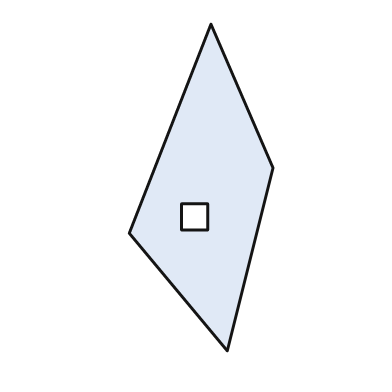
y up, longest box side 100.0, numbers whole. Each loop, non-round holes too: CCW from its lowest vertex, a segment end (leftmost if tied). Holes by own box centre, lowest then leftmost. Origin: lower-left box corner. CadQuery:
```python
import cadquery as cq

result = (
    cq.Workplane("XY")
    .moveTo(30.0, 0.0)
    .lineTo(44.0, 56.0)
    .lineTo(25.0, 100.0)
    .lineTo(0.0, 36.0)
    .close()
    .moveTo(16.0, 37.0)
    .lineTo(24.0, 37.0)
    .lineTo(24.0, 45.0)
    .lineTo(16.0, 45.0)
    .close()
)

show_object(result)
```